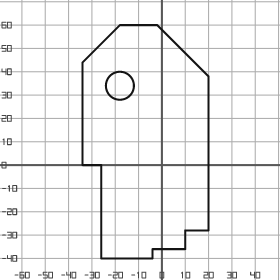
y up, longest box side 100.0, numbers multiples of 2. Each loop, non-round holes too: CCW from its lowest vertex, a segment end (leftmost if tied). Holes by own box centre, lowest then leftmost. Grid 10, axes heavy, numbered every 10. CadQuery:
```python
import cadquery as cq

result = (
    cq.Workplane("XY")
    .moveTo(-26.0, -40.0)
    .lineTo(-4.0, -40.0)
    .lineTo(-4.0, -36.0)
    .lineTo(10.0, -36.0)
    .lineTo(10.0, -28.0)
    .lineTo(20.0, -28.0)
    .lineTo(20.0, 38.0)
    .lineTo(-2.0, 60.0)
    .lineTo(-18.0, 60.0)
    .lineTo(-34.0, 44.0)
    .lineTo(-34.0, 0.0)
    .lineTo(-26.0, 0.0)
    .close()
    .moveTo(-18.0, 34.0)
    .circle(6.0)
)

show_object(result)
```